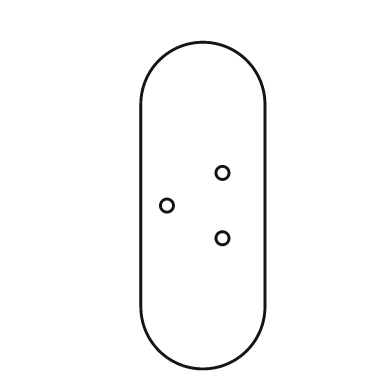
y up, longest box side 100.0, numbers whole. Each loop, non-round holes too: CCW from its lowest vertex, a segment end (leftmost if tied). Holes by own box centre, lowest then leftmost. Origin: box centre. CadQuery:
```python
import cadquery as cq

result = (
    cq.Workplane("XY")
    .moveTo(-19.0, -31.0)
    .threePointArc((0.0, -50.0), (19.0, -31.0))
    .lineTo(19.0, 31.0)
    .threePointArc((0.0, 50.0), (-19.0, 31.0))
    .close()
    .moveTo(6.0, -10.0)
    .circle(2.0)
    .moveTo(-11.0, 0.0)
    .circle(2.0)
    .moveTo(6.0, 10.0)
    .circle(2.0)
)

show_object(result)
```